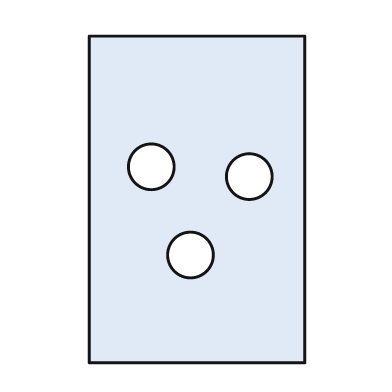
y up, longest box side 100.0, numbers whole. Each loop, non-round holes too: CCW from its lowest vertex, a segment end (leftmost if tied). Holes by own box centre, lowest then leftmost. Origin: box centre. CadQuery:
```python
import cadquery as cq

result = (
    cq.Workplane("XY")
    .moveTo(-33.0, -50.0)
    .lineTo(33.0, -50.0)
    .lineTo(33.0, 50.0)
    .lineTo(-33.0, 50.0)
    .close()
    .moveTo(-2.0, -17.0)
    .circle(7.0)
    .moveTo(16.0, 7.0)
    .circle(7.0)
    .moveTo(-14.0, 10.0)
    .circle(7.0)
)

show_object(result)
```